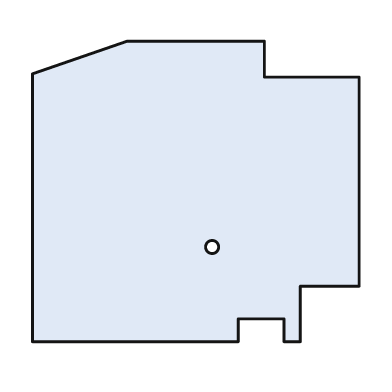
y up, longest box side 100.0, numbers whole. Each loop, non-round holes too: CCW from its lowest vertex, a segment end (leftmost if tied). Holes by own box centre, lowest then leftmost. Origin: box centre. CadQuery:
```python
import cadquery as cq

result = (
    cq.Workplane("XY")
    .moveTo(-50.0, -46.0)
    .lineTo(13.0, -46.0)
    .lineTo(13.0, -39.0)
    .lineTo(27.0, -39.0)
    .lineTo(27.0, -46.0)
    .lineTo(32.0, -46.0)
    .lineTo(32.0, -29.0)
    .lineTo(50.0, -29.0)
    .lineTo(50.0, 35.0)
    .lineTo(21.0, 35.0)
    .lineTo(21.0, 46.0)
    .lineTo(-21.0, 46.0)
    .lineTo(-50.0, 36.0)
    .close()
    .moveTo(5.0, -17.0)
    .circle(2.0)
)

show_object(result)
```